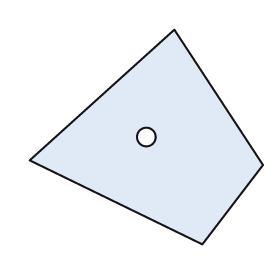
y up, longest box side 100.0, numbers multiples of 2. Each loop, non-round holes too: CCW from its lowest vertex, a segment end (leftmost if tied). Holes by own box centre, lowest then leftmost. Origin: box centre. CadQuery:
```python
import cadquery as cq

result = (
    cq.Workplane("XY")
    .moveTo(24.0, -46.0)
    .lineTo(50.0, -12.0)
    .lineTo(12.0, 46.0)
    .lineTo(-50.0, -10.0)
    .close()
    .moveTo(0.0, 0.0)
    .circle(4.0)
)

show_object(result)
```